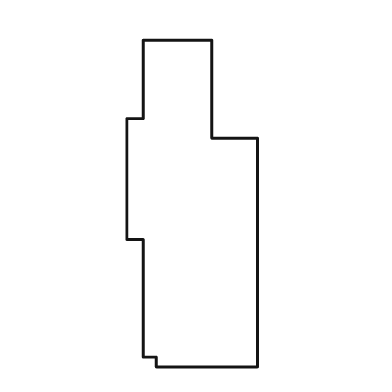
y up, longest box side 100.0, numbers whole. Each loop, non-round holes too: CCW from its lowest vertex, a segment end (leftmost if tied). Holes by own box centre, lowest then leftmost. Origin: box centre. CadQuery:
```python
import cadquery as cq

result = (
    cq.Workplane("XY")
    .moveTo(-11.0, -50.0)
    .lineTo(20.0, -50.0)
    .lineTo(20.0, 20.0)
    .lineTo(6.0, 20.0)
    .lineTo(6.0, 50.0)
    .lineTo(-15.0, 50.0)
    .lineTo(-15.0, 26.0)
    .lineTo(-20.0, 26.0)
    .lineTo(-20.0, -11.0)
    .lineTo(-15.0, -11.0)
    .lineTo(-15.0, -47.0)
    .lineTo(-11.0, -47.0)
    .close()
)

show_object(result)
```